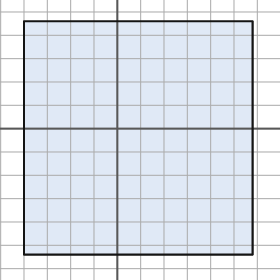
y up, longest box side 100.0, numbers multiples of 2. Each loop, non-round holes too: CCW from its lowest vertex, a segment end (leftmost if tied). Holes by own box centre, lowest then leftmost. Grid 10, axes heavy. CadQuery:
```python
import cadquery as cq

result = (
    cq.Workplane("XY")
    .moveTo(-40.0, -54.0)
    .lineTo(58.0, -54.0)
    .lineTo(58.0, 46.0)
    .lineTo(-40.0, 46.0)
    .close()
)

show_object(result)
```